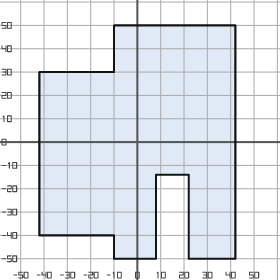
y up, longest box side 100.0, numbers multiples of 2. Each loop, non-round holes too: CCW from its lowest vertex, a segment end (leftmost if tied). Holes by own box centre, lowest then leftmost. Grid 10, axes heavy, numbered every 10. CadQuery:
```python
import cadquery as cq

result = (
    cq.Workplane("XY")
    .moveTo(-10.0, -50.0)
    .lineTo(8.0, -50.0)
    .lineTo(8.0, -14.0)
    .lineTo(22.0, -14.0)
    .lineTo(22.0, -50.0)
    .lineTo(42.0, -50.0)
    .lineTo(42.0, 50.0)
    .lineTo(-10.0, 50.0)
    .lineTo(-10.0, 30.0)
    .lineTo(-42.0, 30.0)
    .lineTo(-42.0, -40.0)
    .lineTo(-10.0, -40.0)
    .close()
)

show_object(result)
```